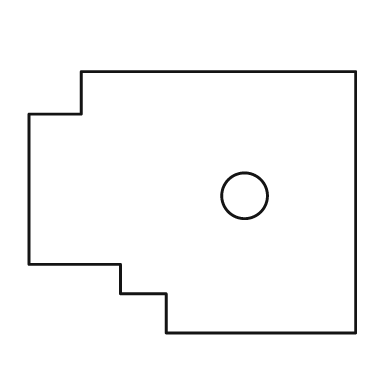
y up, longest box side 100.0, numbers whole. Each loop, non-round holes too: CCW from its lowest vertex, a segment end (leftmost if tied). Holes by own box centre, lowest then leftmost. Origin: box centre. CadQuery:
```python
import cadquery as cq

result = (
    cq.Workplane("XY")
    .moveTo(-8.0, -40.0)
    .lineTo(50.0, -40.0)
    .lineTo(50.0, 40.0)
    .lineTo(-34.0, 40.0)
    .lineTo(-34.0, 27.0)
    .lineTo(-50.0, 27.0)
    .lineTo(-50.0, -19.0)
    .lineTo(-22.0, -19.0)
    .lineTo(-22.0, -28.0)
    .lineTo(-8.0, -28.0)
    .close()
    .moveTo(16.0, 2.0)
    .circle(7.0)
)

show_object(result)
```